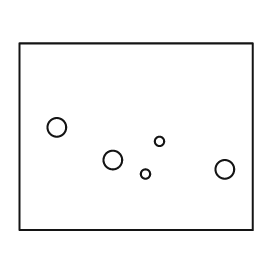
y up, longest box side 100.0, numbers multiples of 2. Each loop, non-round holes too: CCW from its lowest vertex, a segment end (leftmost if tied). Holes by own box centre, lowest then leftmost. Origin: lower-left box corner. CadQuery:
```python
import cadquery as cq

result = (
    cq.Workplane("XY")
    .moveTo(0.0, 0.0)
    .lineTo(100.0, 0.0)
    .lineTo(100.0, 80.0)
    .lineTo(0.0, 80.0)
    .close()
    .moveTo(54.0, 24.0)
    .circle(2.0)
    .moveTo(88.0, 26.0)
    .circle(4.0)
    .moveTo(40.0, 30.0)
    .circle(4.0)
    .moveTo(60.0, 38.0)
    .circle(2.0)
    .moveTo(16.0, 44.0)
    .circle(4.0)
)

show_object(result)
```